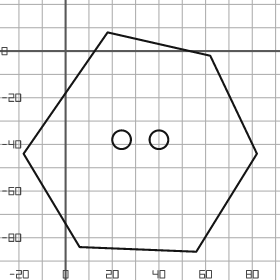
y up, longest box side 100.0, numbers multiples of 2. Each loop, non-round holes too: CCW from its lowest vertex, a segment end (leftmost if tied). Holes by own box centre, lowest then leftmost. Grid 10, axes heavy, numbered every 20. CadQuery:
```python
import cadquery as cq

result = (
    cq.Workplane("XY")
    .moveTo(56.0, -86.0)
    .lineTo(82.0, -44.0)
    .lineTo(62.0, -2.0)
    .lineTo(18.0, 8.0)
    .lineTo(-18.0, -44.0)
    .lineTo(6.0, -84.0)
    .close()
    .moveTo(24.0, -38.0)
    .circle(4.0)
    .moveTo(40.0, -38.0)
    .circle(4.0)
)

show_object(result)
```